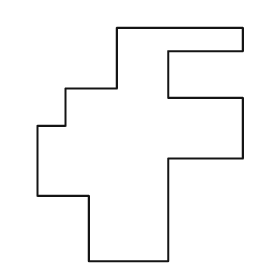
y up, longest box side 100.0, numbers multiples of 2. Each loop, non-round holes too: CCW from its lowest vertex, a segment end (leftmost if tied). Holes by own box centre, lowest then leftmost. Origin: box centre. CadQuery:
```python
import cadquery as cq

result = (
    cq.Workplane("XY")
    .moveTo(-22.0, -50.0)
    .lineTo(12.0, -50.0)
    .lineTo(12.0, -6.0)
    .lineTo(44.0, -6.0)
    .lineTo(44.0, 20.0)
    .lineTo(12.0, 20.0)
    .lineTo(12.0, 40.0)
    .lineTo(44.0, 40.0)
    .lineTo(44.0, 50.0)
    .lineTo(-10.0, 50.0)
    .lineTo(-10.0, 24.0)
    .lineTo(-32.0, 24.0)
    .lineTo(-32.0, 8.0)
    .lineTo(-44.0, 8.0)
    .lineTo(-44.0, -22.0)
    .lineTo(-22.0, -22.0)
    .close()
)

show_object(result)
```